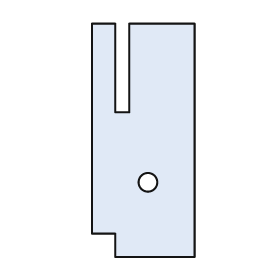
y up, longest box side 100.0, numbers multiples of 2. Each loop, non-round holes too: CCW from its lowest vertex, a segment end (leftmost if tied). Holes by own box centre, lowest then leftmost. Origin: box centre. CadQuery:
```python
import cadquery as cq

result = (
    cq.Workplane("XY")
    .moveTo(-12.0, -50.0)
    .lineTo(22.0, -50.0)
    .lineTo(22.0, 50.0)
    .lineTo(-6.0, 50.0)
    .lineTo(-6.0, 12.0)
    .lineTo(-12.0, 12.0)
    .lineTo(-12.0, 50.0)
    .lineTo(-22.0, 50.0)
    .lineTo(-22.0, -40.0)
    .lineTo(-12.0, -40.0)
    .close()
    .moveTo(2.0, -18.0)
    .circle(4.0)
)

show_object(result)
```